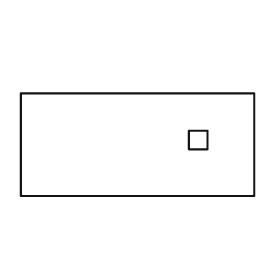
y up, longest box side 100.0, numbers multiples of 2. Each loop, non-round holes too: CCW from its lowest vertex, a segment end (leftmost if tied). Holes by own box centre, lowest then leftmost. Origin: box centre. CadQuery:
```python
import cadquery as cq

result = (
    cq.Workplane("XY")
    .moveTo(-50.0, -22.0)
    .lineTo(50.0, -22.0)
    .lineTo(50.0, 22.0)
    .lineTo(-50.0, 22.0)
    .close()
    .moveTo(22.0, -2.0)
    .lineTo(30.0, -2.0)
    .lineTo(30.0, 6.0)
    .lineTo(22.0, 6.0)
    .close()
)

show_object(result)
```